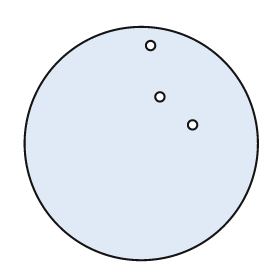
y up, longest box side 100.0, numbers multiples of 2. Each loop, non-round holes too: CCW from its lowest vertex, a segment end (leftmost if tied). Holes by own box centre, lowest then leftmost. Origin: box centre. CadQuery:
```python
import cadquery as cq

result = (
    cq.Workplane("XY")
    .moveTo(0.0, 0.0)
    .circle(50.0)
    .moveTo(22.0, 8.0)
    .circle(2.0)
    .moveTo(8.0, 20.0)
    .circle(2.0)
    .moveTo(4.0, 42.0)
    .circle(2.0)
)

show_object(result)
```